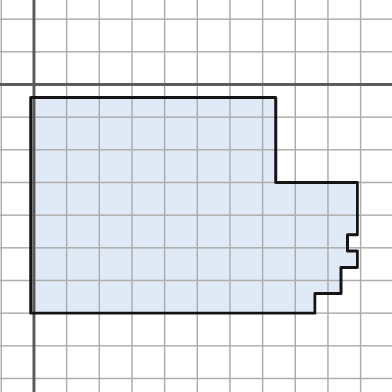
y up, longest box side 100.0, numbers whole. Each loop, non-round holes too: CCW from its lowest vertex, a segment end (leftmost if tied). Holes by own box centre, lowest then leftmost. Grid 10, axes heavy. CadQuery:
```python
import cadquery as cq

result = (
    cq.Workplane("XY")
    .moveTo(-1.0, -70.0)
    .lineTo(86.0, -70.0)
    .lineTo(86.0, -64.0)
    .lineTo(94.0, -64.0)
    .lineTo(94.0, -56.0)
    .lineTo(99.0, -56.0)
    .lineTo(99.0, -51.0)
    .lineTo(96.0, -51.0)
    .lineTo(96.0, -46.0)
    .lineTo(99.0, -46.0)
    .lineTo(99.0, -30.0)
    .lineTo(74.0, -30.0)
    .lineTo(74.0, -4.0)
    .lineTo(-1.0, -4.0)
    .close()
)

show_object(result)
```